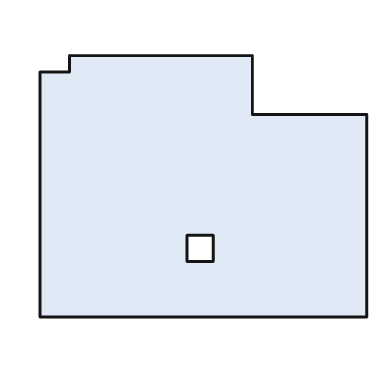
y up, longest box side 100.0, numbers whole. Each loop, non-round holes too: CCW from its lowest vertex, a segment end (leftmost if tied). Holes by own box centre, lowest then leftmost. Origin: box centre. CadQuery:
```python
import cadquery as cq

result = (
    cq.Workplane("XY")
    .moveTo(-50.0, -40.0)
    .lineTo(50.0, -40.0)
    .lineTo(50.0, 22.0)
    .lineTo(15.0, 22.0)
    .lineTo(15.0, 40.0)
    .lineTo(-41.0, 40.0)
    .lineTo(-41.0, 35.0)
    .lineTo(-50.0, 35.0)
    .close()
    .moveTo(-5.0, -23.0)
    .lineTo(3.0, -23.0)
    .lineTo(3.0, -15.0)
    .lineTo(-5.0, -15.0)
    .close()
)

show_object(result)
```